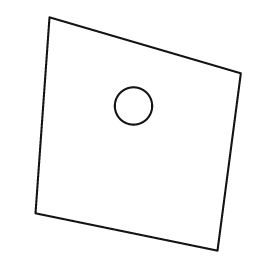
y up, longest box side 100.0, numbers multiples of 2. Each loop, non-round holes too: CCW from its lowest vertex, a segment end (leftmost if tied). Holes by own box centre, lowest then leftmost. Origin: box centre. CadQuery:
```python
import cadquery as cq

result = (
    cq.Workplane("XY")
    .moveTo(34.0, -50.0)
    .lineTo(44.0, 26.0)
    .lineTo(-38.0, 50.0)
    .lineTo(-44.0, -34.0)
    .close()
    .moveTo(-2.0, 12.0)
    .circle(8.0)
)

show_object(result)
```